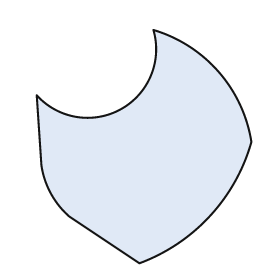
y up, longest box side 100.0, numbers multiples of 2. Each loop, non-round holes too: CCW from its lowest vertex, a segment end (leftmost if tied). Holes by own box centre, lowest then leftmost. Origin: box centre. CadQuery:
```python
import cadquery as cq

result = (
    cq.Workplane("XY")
    .moveTo(-2.0, -50.0)
    .threePointArc((28.0, -30.0), (46.0, 2.0))
    .threePointArc((32.0, 32.0), (4.0, 50.0))
    .threePointArc((-10.0, 16.0), (-46.0, 22.0))
    .lineTo(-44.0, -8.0)
    .threePointArc((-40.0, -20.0), (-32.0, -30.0))
    .close()
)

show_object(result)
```